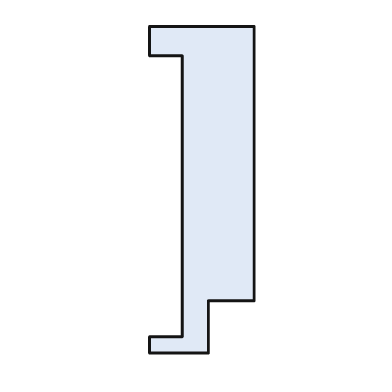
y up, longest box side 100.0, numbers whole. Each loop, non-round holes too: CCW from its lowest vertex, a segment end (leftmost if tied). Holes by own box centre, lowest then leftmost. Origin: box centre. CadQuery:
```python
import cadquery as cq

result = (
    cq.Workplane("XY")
    .moveTo(-16.0, -50.0)
    .lineTo(2.0, -50.0)
    .lineTo(2.0, -34.0)
    .lineTo(16.0, -34.0)
    .lineTo(16.0, 50.0)
    .lineTo(-16.0, 50.0)
    .lineTo(-16.0, 41.0)
    .lineTo(-6.0, 41.0)
    .lineTo(-6.0, -45.0)
    .lineTo(-16.0, -45.0)
    .close()
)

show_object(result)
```